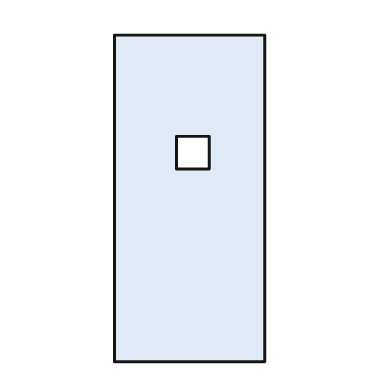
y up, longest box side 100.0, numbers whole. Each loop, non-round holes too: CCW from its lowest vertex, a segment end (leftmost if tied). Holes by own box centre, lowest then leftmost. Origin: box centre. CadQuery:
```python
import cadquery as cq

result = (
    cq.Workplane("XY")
    .moveTo(-23.0, -50.0)
    .lineTo(23.0, -50.0)
    .lineTo(23.0, 50.0)
    .lineTo(-23.0, 50.0)
    .close()
    .moveTo(-4.0, 9.0)
    .lineTo(6.0, 9.0)
    .lineTo(6.0, 19.0)
    .lineTo(-4.0, 19.0)
    .close()
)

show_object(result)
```